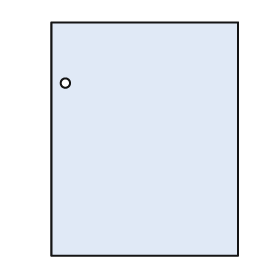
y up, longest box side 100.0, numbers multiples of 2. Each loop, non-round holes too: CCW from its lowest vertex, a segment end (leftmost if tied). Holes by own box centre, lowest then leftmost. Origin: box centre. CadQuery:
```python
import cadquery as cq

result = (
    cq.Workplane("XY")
    .moveTo(-40.0, -50.0)
    .lineTo(40.0, -50.0)
    .lineTo(40.0, 50.0)
    .lineTo(-40.0, 50.0)
    .close()
    .moveTo(-34.0, 24.0)
    .circle(2.0)
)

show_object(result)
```